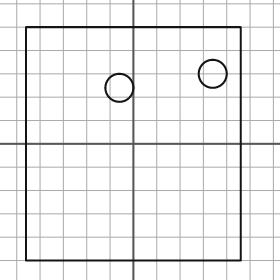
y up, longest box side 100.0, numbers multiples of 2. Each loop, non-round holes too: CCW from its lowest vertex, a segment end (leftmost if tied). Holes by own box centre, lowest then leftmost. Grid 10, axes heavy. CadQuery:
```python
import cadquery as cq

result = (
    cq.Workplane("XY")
    .moveTo(-46.0, -50.0)
    .lineTo(46.0, -50.0)
    .lineTo(46.0, 50.0)
    .lineTo(-46.0, 50.0)
    .close()
    .moveTo(-6.0, 24.0)
    .circle(6.0)
    .moveTo(34.0, 30.0)
    .circle(6.0)
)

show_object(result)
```